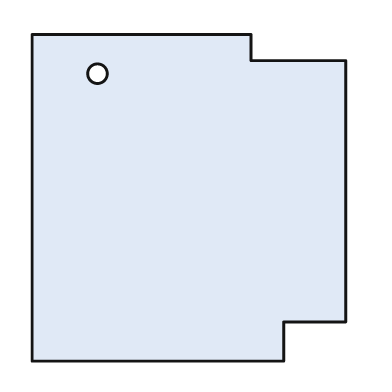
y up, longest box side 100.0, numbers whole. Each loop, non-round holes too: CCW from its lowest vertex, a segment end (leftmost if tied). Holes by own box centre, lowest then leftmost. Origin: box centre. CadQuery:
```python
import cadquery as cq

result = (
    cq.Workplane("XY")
    .moveTo(-48.0, -50.0)
    .lineTo(29.0, -50.0)
    .lineTo(29.0, -38.0)
    .lineTo(48.0, -38.0)
    .lineTo(48.0, 42.0)
    .lineTo(19.0, 42.0)
    .lineTo(19.0, 50.0)
    .lineTo(-48.0, 50.0)
    .close()
    .moveTo(-28.0, 38.0)
    .circle(3.0)
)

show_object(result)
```